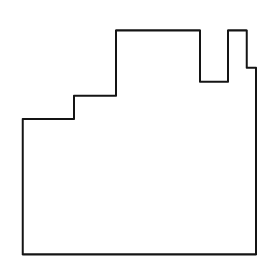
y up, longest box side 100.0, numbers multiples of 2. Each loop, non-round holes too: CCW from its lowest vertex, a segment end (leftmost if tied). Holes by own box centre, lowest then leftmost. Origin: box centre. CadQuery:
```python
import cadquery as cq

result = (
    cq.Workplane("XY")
    .moveTo(-50.0, -48.0)
    .lineTo(50.0, -48.0)
    .lineTo(50.0, 32.0)
    .lineTo(46.0, 32.0)
    .lineTo(46.0, 48.0)
    .lineTo(38.0, 48.0)
    .lineTo(38.0, 26.0)
    .lineTo(26.0, 26.0)
    .lineTo(26.0, 48.0)
    .lineTo(-10.0, 48.0)
    .lineTo(-10.0, 20.0)
    .lineTo(-28.0, 20.0)
    .lineTo(-28.0, 10.0)
    .lineTo(-50.0, 10.0)
    .close()
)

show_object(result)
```